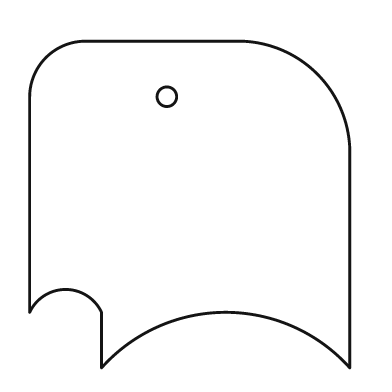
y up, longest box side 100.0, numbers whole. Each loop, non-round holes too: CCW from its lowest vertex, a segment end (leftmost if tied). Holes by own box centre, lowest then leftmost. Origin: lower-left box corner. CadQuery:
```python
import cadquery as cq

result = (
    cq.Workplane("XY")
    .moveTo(22.0, 0.0)
    .threePointArc((60.0, 17.0), (98.0, 0.0))
    .lineTo(98.0, 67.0)
    .threePointArc((88.0, 90.0), (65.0, 100.0))
    .lineTo(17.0, 100.0)
    .threePointArc((5.0, 95.0), (0.0, 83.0))
    .lineTo(0.0, 17.0)
    .threePointArc((11.0, 24.0), (22.0, 17.0))
    .close()
    .moveTo(42.0, 83.0)
    .circle(3.0)
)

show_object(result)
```